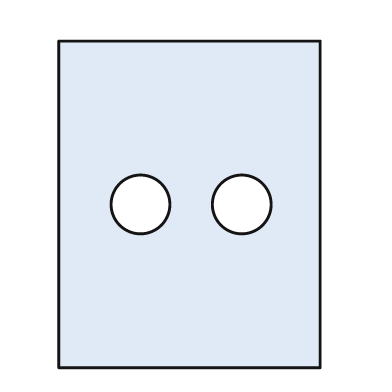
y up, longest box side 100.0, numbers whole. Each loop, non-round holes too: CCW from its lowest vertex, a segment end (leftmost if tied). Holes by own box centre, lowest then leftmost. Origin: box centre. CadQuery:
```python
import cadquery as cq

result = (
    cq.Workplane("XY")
    .moveTo(-40.0, -50.0)
    .lineTo(40.0, -50.0)
    .lineTo(40.0, 50.0)
    .lineTo(-40.0, 50.0)
    .close()
    .moveTo(-15.0, 0.0)
    .circle(9.0)
    .moveTo(16.0, 0.0)
    .circle(9.0)
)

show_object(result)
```